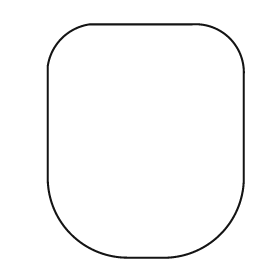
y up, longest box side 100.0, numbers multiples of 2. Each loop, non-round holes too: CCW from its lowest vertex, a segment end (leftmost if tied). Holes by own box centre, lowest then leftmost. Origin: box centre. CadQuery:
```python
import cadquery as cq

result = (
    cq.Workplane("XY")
    .moveTo(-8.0, -50.0)
    .lineTo(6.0, -50.0)
    .threePointArc((32.0, -40.0), (42.0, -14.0))
    .lineTo(42.0, 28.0)
    .threePointArc((36.0, 44.0), (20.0, 50.0))
    .lineTo(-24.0, 50.0)
    .threePointArc((-36.0, 44.0), (-42.0, 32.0))
    .lineTo(-42.0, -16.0)
    .threePointArc((-32.0, -40.0), (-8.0, -50.0))
    .close()
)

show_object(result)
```